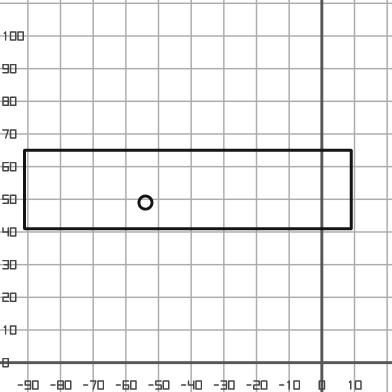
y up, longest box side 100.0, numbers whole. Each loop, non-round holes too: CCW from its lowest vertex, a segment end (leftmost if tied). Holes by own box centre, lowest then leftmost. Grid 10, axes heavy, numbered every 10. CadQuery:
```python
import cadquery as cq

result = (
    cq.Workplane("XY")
    .moveTo(-91.0, 41.0)
    .lineTo(9.0, 41.0)
    .lineTo(9.0, 65.0)
    .lineTo(-91.0, 65.0)
    .close()
    .moveTo(-54.0, 49.0)
    .circle(2.0)
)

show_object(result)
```